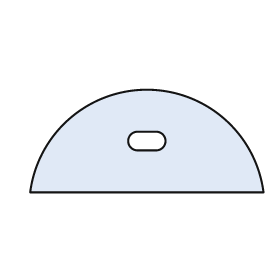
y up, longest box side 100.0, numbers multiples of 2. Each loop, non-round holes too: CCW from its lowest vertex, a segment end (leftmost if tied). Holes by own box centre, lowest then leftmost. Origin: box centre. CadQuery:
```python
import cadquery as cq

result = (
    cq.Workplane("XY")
    .moveTo(-50.0, -22.0)
    .lineTo(50.0, -22.0)
    .threePointArc((0.0, 22.0), (-50.0, -22.0))
    .close()
    .moveTo(-4.0, -4.0)
    .lineTo(4.0, -4.0)
    .threePointArc((8.0, 0.0), (4.0, 4.0))
    .lineTo(-4.0, 4.0)
    .threePointArc((-8.0, 0.0), (-4.0, -4.0))
    .close()
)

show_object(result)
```